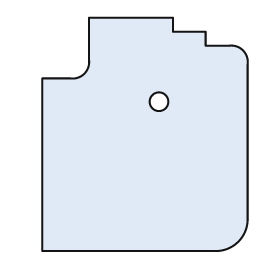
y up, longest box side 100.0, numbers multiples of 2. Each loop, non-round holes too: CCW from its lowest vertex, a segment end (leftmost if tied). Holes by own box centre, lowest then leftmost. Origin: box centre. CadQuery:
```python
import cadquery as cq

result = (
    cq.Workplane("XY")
    .moveTo(-44.0, -50.0)
    .lineTo(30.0, -50.0)
    .threePointArc((40.0, -46.0), (44.0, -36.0))
    .lineTo(44.0, 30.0)
    .threePointArc((42.0, 36.0), (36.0, 38.0))
    .lineTo(26.0, 38.0)
    .lineTo(26.0, 44.0)
    .lineTo(12.0, 44.0)
    .lineTo(12.0, 50.0)
    .lineTo(-24.0, 50.0)
    .lineTo(-24.0, 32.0)
    .threePointArc((-26.0, 26.0), (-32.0, 24.0))
    .lineTo(-44.0, 24.0)
    .close()
    .moveTo(6.0, 14.0)
    .circle(4.0)
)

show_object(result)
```